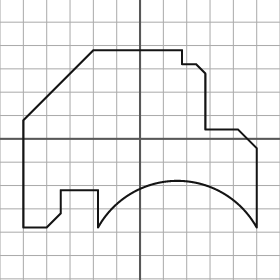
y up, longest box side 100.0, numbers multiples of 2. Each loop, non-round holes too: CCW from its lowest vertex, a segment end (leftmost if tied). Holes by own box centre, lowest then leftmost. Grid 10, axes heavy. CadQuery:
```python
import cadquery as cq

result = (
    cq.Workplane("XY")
    .moveTo(-50.0, -38.0)
    .lineTo(-40.0, -38.0)
    .lineTo(-34.0, -32.0)
    .lineTo(-34.0, -22.0)
    .lineTo(-18.0, -22.0)
    .lineTo(-18.0, -38.0)
    .threePointArc((16.0, -18.0), (50.0, -38.0))
    .lineTo(50.0, -4.0)
    .lineTo(42.0, 4.0)
    .lineTo(28.0, 4.0)
    .lineTo(28.0, 28.0)
    .lineTo(24.0, 32.0)
    .lineTo(18.0, 32.0)
    .lineTo(18.0, 38.0)
    .lineTo(-20.0, 38.0)
    .lineTo(-50.0, 8.0)
    .close()
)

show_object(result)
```